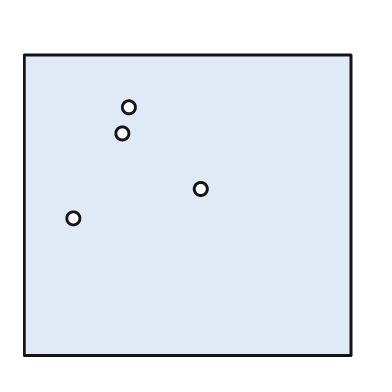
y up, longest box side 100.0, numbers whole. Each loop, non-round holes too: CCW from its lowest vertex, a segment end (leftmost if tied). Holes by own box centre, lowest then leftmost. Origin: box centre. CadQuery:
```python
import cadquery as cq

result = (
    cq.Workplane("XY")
    .moveTo(-50.0, -46.0)
    .lineTo(50.0, -46.0)
    .lineTo(50.0, 46.0)
    .lineTo(-50.0, 46.0)
    .close()
    .moveTo(-35.0, -4.0)
    .circle(2.0)
    .moveTo(4.0, 5.0)
    .circle(2.0)
    .moveTo(-20.0, 22.0)
    .circle(2.0)
    .moveTo(-18.0, 30.0)
    .circle(2.0)
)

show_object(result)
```